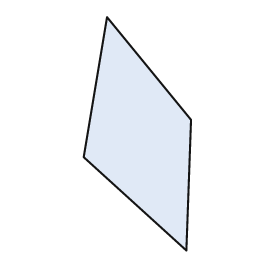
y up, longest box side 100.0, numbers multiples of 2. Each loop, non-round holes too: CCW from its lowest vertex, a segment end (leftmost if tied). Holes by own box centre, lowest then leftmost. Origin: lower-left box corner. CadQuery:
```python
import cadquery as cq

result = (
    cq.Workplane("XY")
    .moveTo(44.0, 0.0)
    .lineTo(46.0, 56.0)
    .lineTo(10.0, 100.0)
    .lineTo(0.0, 40.0)
    .close()
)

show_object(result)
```